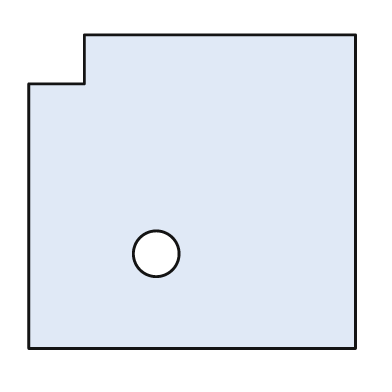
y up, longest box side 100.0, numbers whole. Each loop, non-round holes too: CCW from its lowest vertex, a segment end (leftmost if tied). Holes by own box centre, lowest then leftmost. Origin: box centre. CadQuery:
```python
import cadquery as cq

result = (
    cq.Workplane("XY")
    .moveTo(-50.0, -48.0)
    .lineTo(50.0, -48.0)
    .lineTo(50.0, 48.0)
    .lineTo(-33.0, 48.0)
    .lineTo(-33.0, 33.0)
    .lineTo(-50.0, 33.0)
    .close()
    .moveTo(-11.0, -19.0)
    .circle(7.0)
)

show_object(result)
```